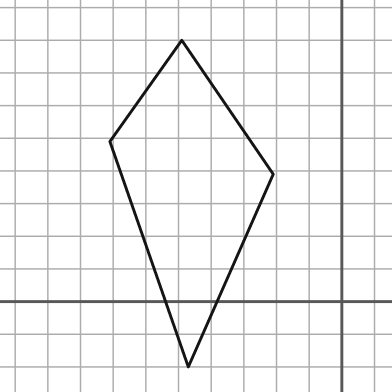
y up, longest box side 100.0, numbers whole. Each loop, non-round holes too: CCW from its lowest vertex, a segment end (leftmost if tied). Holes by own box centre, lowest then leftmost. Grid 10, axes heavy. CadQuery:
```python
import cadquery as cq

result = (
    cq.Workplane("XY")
    .moveTo(-47.0, -20.0)
    .lineTo(-21.0, 39.0)
    .lineTo(-49.0, 80.0)
    .lineTo(-71.0, 49.0)
    .close()
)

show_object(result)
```